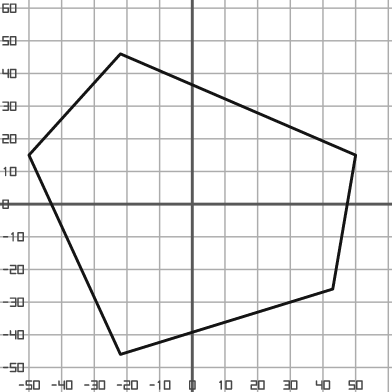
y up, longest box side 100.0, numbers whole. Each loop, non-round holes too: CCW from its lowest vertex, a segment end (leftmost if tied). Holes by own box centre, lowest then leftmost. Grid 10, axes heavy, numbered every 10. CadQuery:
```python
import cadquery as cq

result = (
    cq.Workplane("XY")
    .moveTo(-22.0, -46.0)
    .lineTo(43.0, -26.0)
    .lineTo(50.0, 15.0)
    .lineTo(-22.0, 46.0)
    .lineTo(-50.0, 15.0)
    .close()
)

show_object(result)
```